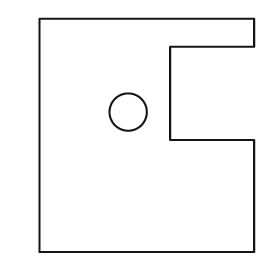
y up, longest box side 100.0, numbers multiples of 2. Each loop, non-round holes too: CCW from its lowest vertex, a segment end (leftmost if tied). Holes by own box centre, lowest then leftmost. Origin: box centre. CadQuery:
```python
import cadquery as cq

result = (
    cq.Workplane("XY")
    .moveTo(-46.0, -50.0)
    .lineTo(46.0, -50.0)
    .lineTo(46.0, -2.0)
    .lineTo(10.0, -2.0)
    .lineTo(10.0, 38.0)
    .lineTo(46.0, 38.0)
    .lineTo(46.0, 50.0)
    .lineTo(-46.0, 50.0)
    .close()
    .moveTo(-8.0, 10.0)
    .circle(8.0)
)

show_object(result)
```